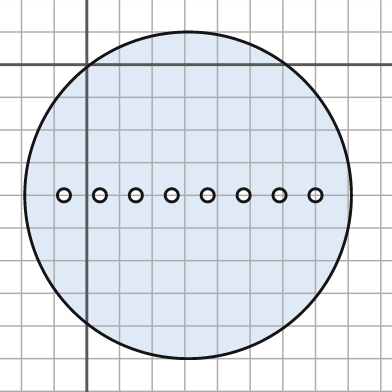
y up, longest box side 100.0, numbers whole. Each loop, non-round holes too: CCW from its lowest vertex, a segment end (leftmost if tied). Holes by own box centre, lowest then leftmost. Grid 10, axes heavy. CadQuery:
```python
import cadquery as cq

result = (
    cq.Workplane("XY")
    .moveTo(31.0, -40.0)
    .circle(50.0)
    .moveTo(-7.0, -40.0)
    .circle(2.0)
    .moveTo(4.0, -40.0)
    .circle(2.0)
    .moveTo(15.0, -40.0)
    .circle(2.0)
    .moveTo(26.0, -40.0)
    .circle(2.0)
    .moveTo(37.0, -40.0)
    .circle(2.0)
    .moveTo(48.0, -40.0)
    .circle(2.0)
    .moveTo(59.0, -40.0)
    .circle(2.0)
    .moveTo(70.0, -40.0)
    .circle(2.0)
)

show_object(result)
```